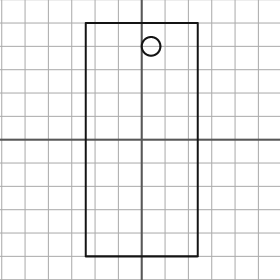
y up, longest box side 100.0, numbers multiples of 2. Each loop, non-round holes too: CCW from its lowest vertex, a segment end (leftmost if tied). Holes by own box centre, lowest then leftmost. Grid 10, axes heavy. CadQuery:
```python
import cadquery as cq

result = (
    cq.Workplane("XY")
    .moveTo(-24.0, -50.0)
    .lineTo(24.0, -50.0)
    .lineTo(24.0, 50.0)
    .lineTo(-24.0, 50.0)
    .close()
    .moveTo(4.0, 40.0)
    .circle(4.0)
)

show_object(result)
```